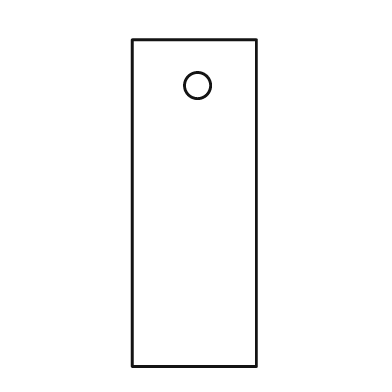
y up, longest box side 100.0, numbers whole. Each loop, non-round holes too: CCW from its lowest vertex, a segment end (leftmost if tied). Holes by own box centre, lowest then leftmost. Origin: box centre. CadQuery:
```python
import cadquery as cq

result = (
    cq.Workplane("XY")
    .moveTo(-19.0, -50.0)
    .lineTo(19.0, -50.0)
    .lineTo(19.0, 50.0)
    .lineTo(-19.0, 50.0)
    .close()
    .moveTo(1.0, 36.0)
    .circle(4.0)
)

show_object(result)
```